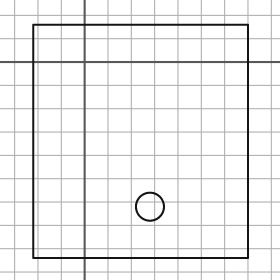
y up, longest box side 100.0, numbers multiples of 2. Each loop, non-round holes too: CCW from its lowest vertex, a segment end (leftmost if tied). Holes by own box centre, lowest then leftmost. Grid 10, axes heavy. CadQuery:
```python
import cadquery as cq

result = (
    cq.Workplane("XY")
    .moveTo(-22.0, -84.0)
    .lineTo(70.0, -84.0)
    .lineTo(70.0, 16.0)
    .lineTo(-22.0, 16.0)
    .close()
    .moveTo(28.0, -62.0)
    .circle(6.0)
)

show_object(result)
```